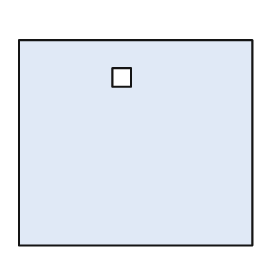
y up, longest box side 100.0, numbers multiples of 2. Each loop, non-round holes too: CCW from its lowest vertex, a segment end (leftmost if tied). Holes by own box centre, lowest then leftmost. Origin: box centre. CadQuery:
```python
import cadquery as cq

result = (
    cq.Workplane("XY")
    .moveTo(-50.0, -44.0)
    .lineTo(50.0, -44.0)
    .lineTo(50.0, 44.0)
    .lineTo(-50.0, 44.0)
    .close()
    .moveTo(-10.0, 24.0)
    .lineTo(-2.0, 24.0)
    .lineTo(-2.0, 32.0)
    .lineTo(-10.0, 32.0)
    .close()
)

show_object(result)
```